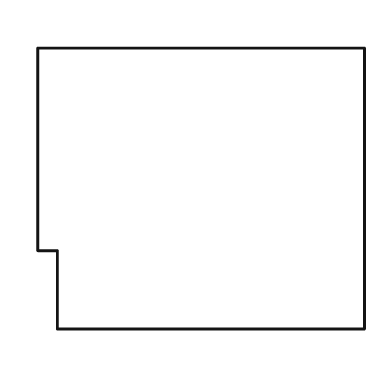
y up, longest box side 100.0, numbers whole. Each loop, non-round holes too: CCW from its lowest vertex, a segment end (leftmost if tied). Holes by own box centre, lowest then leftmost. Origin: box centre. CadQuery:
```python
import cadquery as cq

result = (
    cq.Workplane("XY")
    .moveTo(-44.0, -43.0)
    .lineTo(50.0, -43.0)
    .lineTo(50.0, 43.0)
    .lineTo(-50.0, 43.0)
    .lineTo(-50.0, -19.0)
    .lineTo(-44.0, -19.0)
    .close()
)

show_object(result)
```